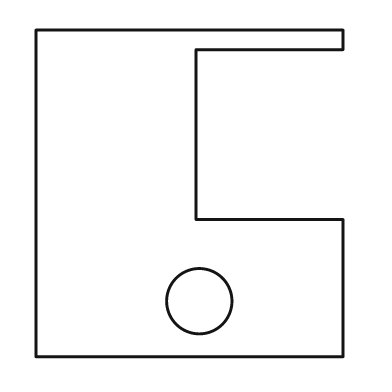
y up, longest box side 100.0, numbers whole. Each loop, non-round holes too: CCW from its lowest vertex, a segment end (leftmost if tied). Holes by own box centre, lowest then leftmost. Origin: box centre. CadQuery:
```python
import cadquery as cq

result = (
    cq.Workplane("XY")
    .moveTo(-47.0, -50.0)
    .lineTo(47.0, -50.0)
    .lineTo(47.0, -8.0)
    .lineTo(2.0, -8.0)
    .lineTo(2.0, 44.0)
    .lineTo(47.0, 44.0)
    .lineTo(47.0, 50.0)
    .lineTo(-47.0, 50.0)
    .close()
    .moveTo(3.0, -33.0)
    .circle(10.0)
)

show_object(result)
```